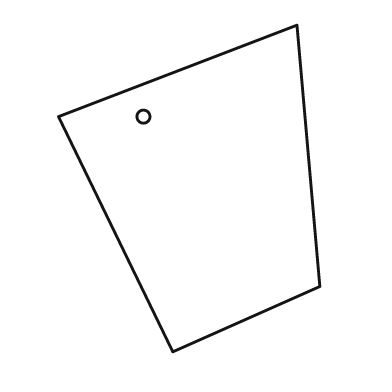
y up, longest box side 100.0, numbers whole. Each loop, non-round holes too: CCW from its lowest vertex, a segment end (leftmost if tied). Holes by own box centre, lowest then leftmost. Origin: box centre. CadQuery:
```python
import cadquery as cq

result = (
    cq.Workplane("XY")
    .moveTo(-5.0, -50.0)
    .lineTo(40.0, -30.0)
    .lineTo(33.0, 50.0)
    .lineTo(-40.0, 22.0)
    .close()
    .moveTo(-14.0, 22.0)
    .circle(2.0)
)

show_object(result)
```